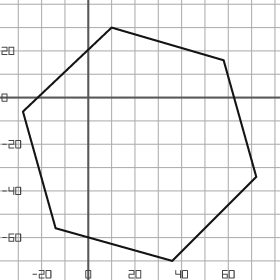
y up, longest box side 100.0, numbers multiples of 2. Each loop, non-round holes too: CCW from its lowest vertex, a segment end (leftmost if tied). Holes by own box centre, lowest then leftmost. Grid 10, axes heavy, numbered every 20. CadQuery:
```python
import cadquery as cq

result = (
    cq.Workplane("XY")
    .moveTo(36.0, -70.0)
    .lineTo(72.0, -34.0)
    .lineTo(58.0, 16.0)
    .lineTo(10.0, 30.0)
    .lineTo(-28.0, -6.0)
    .lineTo(-14.0, -56.0)
    .close()
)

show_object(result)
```